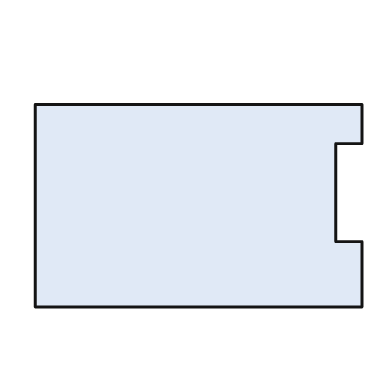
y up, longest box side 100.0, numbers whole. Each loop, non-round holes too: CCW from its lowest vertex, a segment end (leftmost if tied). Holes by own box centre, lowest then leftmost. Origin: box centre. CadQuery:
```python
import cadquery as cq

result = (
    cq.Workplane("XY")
    .moveTo(-50.0, -31.0)
    .lineTo(50.0, -31.0)
    .lineTo(50.0, -11.0)
    .lineTo(42.0, -11.0)
    .lineTo(42.0, 19.0)
    .lineTo(50.0, 19.0)
    .lineTo(50.0, 31.0)
    .lineTo(-50.0, 31.0)
    .close()
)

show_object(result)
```